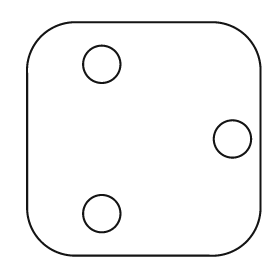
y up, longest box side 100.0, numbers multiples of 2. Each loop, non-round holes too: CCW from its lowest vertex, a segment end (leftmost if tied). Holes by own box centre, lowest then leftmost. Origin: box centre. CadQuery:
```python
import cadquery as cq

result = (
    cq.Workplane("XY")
    .moveTo(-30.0, -50.0)
    .lineTo(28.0, -50.0)
    .threePointArc((44.0, -44.0), (50.0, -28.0))
    .lineTo(50.0, 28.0)
    .threePointArc((44.0, 44.0), (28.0, 50.0))
    .lineTo(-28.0, 50.0)
    .threePointArc((-44.0, 44.0), (-50.0, 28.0))
    .lineTo(-50.0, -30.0)
    .threePointArc((-44.0, -44.0), (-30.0, -50.0))
    .close()
    .moveTo(-18.0, -32.0)
    .circle(8.0)
    .moveTo(38.0, 0.0)
    .circle(8.0)
    .moveTo(-18.0, 32.0)
    .circle(8.0)
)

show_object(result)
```